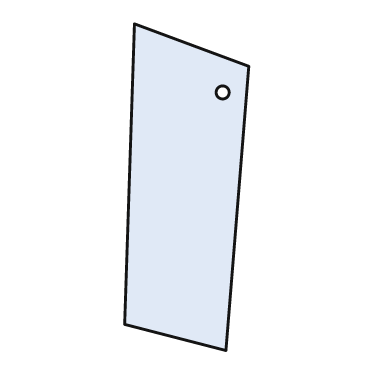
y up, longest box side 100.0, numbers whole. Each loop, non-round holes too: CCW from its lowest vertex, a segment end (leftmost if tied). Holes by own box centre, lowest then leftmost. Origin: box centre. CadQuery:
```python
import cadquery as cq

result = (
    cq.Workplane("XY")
    .moveTo(12.0, -50.0)
    .lineTo(19.0, 37.0)
    .lineTo(-16.0, 50.0)
    .lineTo(-19.0, -42.0)
    .close()
    .moveTo(11.0, 29.0)
    .circle(2.0)
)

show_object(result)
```